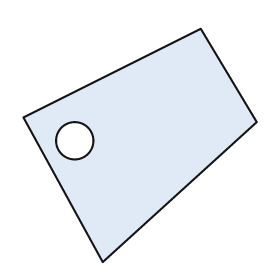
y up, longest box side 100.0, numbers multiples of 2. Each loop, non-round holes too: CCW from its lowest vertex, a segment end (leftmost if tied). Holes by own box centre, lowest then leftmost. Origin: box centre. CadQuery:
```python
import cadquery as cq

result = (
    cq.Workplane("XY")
    .moveTo(-16.0, -50.0)
    .lineTo(50.0, 10.0)
    .lineTo(26.0, 50.0)
    .lineTo(-50.0, 12.0)
    .close()
    .moveTo(-28.0, 2.0)
    .circle(8.0)
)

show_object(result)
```